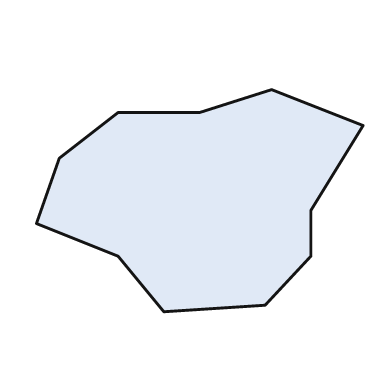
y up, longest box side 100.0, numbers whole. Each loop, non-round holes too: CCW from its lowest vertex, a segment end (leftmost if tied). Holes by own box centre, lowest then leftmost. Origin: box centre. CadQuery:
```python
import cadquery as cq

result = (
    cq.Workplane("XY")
    .moveTo(-11.0, -34.0)
    .lineTo(20.0, -32.0)
    .lineTo(34.0, -17.0)
    .lineTo(34.0, -3.0)
    .lineTo(50.0, 23.0)
    .lineTo(22.0, 34.0)
    .lineTo(0.0, 27.0)
    .lineTo(-25.0, 27.0)
    .lineTo(-43.0, 13.0)
    .lineTo(-50.0, -7.0)
    .lineTo(-25.0, -17.0)
    .close()
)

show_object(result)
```